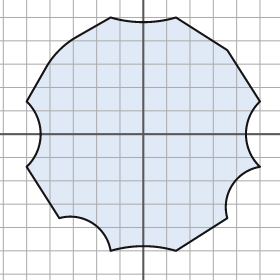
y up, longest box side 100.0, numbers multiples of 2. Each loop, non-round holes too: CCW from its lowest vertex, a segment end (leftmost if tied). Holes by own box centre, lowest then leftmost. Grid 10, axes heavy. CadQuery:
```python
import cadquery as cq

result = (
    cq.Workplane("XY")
    .moveTo(-14.0, -50.0)
    .threePointArc((0.0, -48.0), (14.0, -50.0))
    .lineTo(36.0, -36.0)
    .threePointArc((38.0, -22.0), (50.0, -14.0))
    .threePointArc((44.0, 0.0), (50.0, 14.0))
    .lineTo(36.0, 36.0)
    .lineTo(14.0, 50.0)
    .threePointArc((0.0, 48.0), (-14.0, 50.0))
    .lineTo(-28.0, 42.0)
    .threePointArc((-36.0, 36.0), (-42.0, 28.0))
    .lineTo(-50.0, 14.0)
    .threePointArc((-44.0, 0.0), (-50.0, -14.0))
    .lineTo(-36.0, -36.0)
    .threePointArc((-22.0, -38.0), (-14.0, -50.0))
    .close()
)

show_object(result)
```